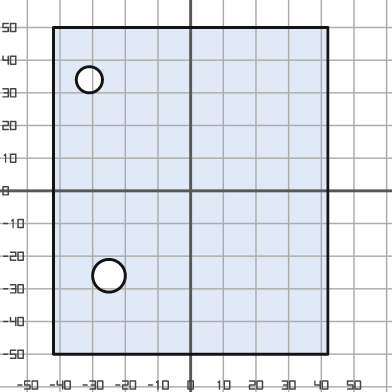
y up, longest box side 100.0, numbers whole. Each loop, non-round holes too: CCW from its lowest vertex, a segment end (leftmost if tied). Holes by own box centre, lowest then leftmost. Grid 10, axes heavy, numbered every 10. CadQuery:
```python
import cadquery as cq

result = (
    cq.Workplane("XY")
    .moveTo(-42.0, -50.0)
    .lineTo(42.0, -50.0)
    .lineTo(42.0, 50.0)
    .lineTo(-42.0, 50.0)
    .close()
    .moveTo(-25.0, -26.0)
    .circle(5.0)
    .moveTo(-31.0, 34.0)
    .circle(4.0)
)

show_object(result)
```